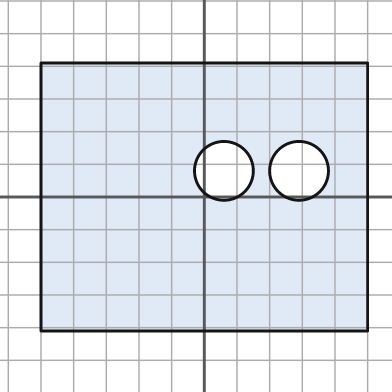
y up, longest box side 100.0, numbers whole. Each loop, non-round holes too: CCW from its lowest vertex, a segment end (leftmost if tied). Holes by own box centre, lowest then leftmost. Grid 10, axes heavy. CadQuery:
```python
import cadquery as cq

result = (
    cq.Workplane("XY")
    .moveTo(-50.0, -41.0)
    .lineTo(50.0, -41.0)
    .lineTo(50.0, 41.0)
    .lineTo(-50.0, 41.0)
    .close()
    .moveTo(6.0, 8.0)
    .circle(9.0)
    .moveTo(29.0, 8.0)
    .circle(9.0)
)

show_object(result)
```